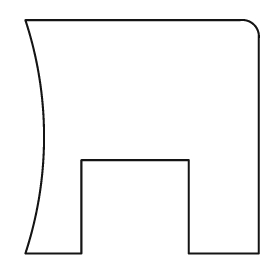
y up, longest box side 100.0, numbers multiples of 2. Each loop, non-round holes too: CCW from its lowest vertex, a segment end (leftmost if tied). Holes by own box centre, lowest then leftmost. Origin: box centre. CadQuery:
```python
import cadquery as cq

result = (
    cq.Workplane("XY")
    .moveTo(-50.0, -50.0)
    .lineTo(-26.0, -50.0)
    .lineTo(-26.0, -10.0)
    .lineTo(20.0, -10.0)
    .lineTo(20.0, -50.0)
    .lineTo(50.0, -50.0)
    .lineTo(50.0, 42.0)
    .threePointArc((48.0, 48.0), (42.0, 50.0))
    .lineTo(-50.0, 50.0)
    .threePointArc((-42.0, 0.0), (-50.0, -50.0))
    .close()
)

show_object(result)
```